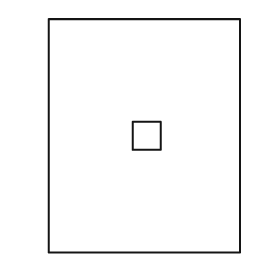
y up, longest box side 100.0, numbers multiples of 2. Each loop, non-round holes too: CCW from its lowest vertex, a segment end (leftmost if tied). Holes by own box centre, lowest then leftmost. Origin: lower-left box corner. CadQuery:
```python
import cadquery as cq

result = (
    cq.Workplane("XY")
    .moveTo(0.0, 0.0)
    .lineTo(82.0, 0.0)
    .lineTo(82.0, 100.0)
    .lineTo(0.0, 100.0)
    .close()
    .moveTo(36.0, 44.0)
    .lineTo(48.0, 44.0)
    .lineTo(48.0, 56.0)
    .lineTo(36.0, 56.0)
    .close()
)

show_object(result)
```